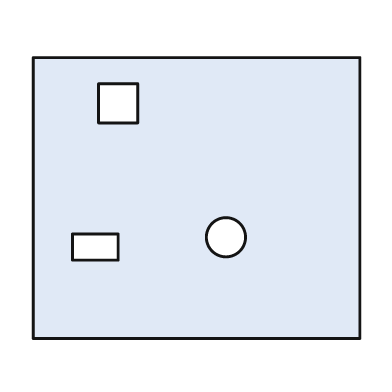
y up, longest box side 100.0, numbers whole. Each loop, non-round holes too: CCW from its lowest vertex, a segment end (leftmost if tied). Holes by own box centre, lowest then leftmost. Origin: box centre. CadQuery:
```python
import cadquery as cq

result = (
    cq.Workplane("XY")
    .moveTo(-50.0, -43.0)
    .lineTo(50.0, -43.0)
    .lineTo(50.0, 43.0)
    .lineTo(-50.0, 43.0)
    .close()
    .moveTo(-38.0, -19.0)
    .lineTo(-24.0, -19.0)
    .lineTo(-24.0, -11.0)
    .lineTo(-38.0, -11.0)
    .close()
    .moveTo(9.0, -12.0)
    .circle(6.0)
    .moveTo(-30.0, 23.0)
    .lineTo(-18.0, 23.0)
    .lineTo(-18.0, 35.0)
    .lineTo(-30.0, 35.0)
    .close()
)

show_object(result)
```